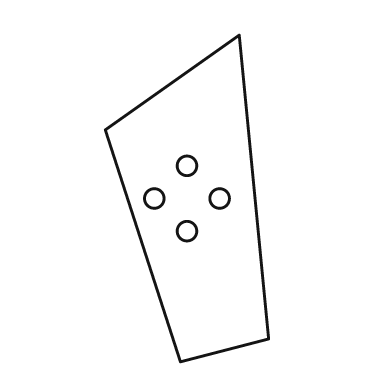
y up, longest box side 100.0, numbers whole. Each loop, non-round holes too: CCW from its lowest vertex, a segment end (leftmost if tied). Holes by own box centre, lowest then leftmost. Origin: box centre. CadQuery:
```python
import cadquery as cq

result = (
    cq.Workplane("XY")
    .moveTo(-2.0, -50.0)
    .lineTo(25.0, -43.0)
    .lineTo(16.0, 50.0)
    .lineTo(-25.0, 21.0)
    .close()
    .moveTo(0.0, -10.0)
    .circle(3.0)
    .moveTo(-10.0, 0.0)
    .circle(3.0)
    .moveTo(10.0, 0.0)
    .circle(3.0)
    .moveTo(0.0, 10.0)
    .circle(3.0)
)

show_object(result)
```